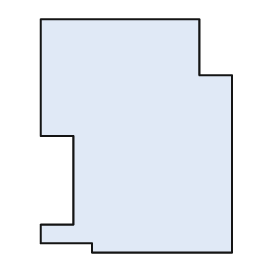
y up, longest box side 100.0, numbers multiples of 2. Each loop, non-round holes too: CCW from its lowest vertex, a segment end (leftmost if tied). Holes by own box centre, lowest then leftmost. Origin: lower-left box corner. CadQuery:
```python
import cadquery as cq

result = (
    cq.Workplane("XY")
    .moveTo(22.0, 0.0)
    .lineTo(82.0, 0.0)
    .lineTo(82.0, 76.0)
    .lineTo(68.0, 76.0)
    .lineTo(68.0, 100.0)
    .lineTo(0.0, 100.0)
    .lineTo(0.0, 50.0)
    .lineTo(14.0, 50.0)
    .lineTo(14.0, 12.0)
    .lineTo(0.0, 12.0)
    .lineTo(0.0, 4.0)
    .lineTo(22.0, 4.0)
    .close()
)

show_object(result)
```